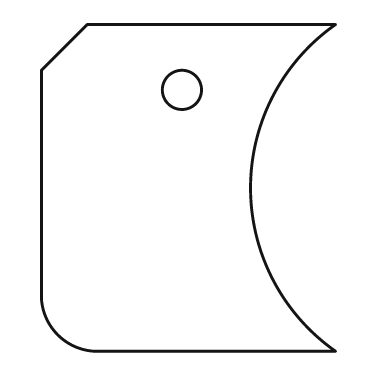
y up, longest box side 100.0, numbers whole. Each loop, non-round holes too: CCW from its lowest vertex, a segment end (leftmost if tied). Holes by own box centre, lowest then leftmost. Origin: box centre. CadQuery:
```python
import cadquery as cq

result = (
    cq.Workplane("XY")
    .moveTo(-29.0, -50.0)
    .lineTo(45.0, -50.0)
    .threePointArc((19.0, 0.0), (45.0, 50.0))
    .lineTo(-31.0, 50.0)
    .lineTo(-45.0, 36.0)
    .lineTo(-45.0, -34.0)
    .threePointArc((-40.0, -45.0), (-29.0, -50.0))
    .close()
    .moveTo(-2.0, 30.0)
    .circle(6.0)
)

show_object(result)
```